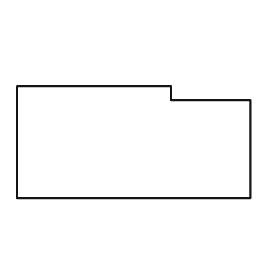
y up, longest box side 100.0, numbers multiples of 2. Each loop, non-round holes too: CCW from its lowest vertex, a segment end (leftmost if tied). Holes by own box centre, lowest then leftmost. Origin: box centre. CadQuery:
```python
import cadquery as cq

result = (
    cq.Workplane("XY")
    .moveTo(-50.0, -24.0)
    .lineTo(50.0, -24.0)
    .lineTo(50.0, 18.0)
    .lineTo(16.0, 18.0)
    .lineTo(16.0, 24.0)
    .lineTo(-50.0, 24.0)
    .close()
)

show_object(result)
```